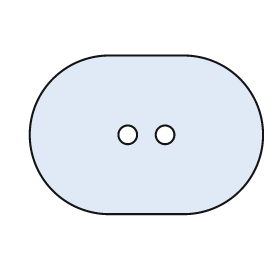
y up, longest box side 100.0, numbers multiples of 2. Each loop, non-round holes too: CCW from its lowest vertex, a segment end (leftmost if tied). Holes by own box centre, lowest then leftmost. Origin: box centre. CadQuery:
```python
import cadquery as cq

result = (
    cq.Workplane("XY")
    .moveTo(-16.0, -34.0)
    .lineTo(16.0, -34.0)
    .threePointArc((50.0, 0.0), (16.0, 34.0))
    .lineTo(-16.0, 34.0)
    .threePointArc((-50.0, 0.0), (-16.0, -34.0))
    .close()
    .moveTo(-8.0, 0.0)
    .circle(4.0)
    .moveTo(8.0, 0.0)
    .circle(4.0)
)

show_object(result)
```